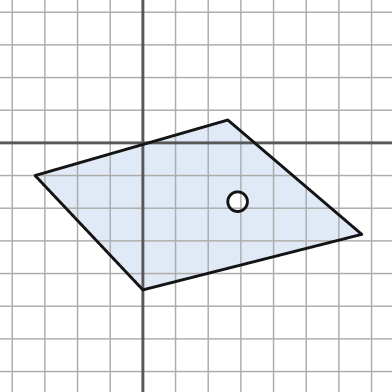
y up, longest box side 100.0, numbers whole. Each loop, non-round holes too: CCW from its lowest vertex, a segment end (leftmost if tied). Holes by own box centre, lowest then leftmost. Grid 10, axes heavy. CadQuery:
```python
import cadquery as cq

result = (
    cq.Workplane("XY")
    .moveTo(0.0, -45.0)
    .lineTo(67.0, -28.0)
    .lineTo(26.0, 7.0)
    .lineTo(-33.0, -10.0)
    .close()
    .moveTo(29.0, -18.0)
    .circle(3.0)
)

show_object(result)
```